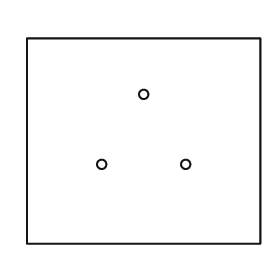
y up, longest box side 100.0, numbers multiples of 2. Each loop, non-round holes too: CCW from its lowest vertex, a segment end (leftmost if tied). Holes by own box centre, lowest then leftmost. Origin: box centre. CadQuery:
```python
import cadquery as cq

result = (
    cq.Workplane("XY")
    .moveTo(-50.0, -44.0)
    .lineTo(50.0, -44.0)
    .lineTo(50.0, 44.0)
    .lineTo(-50.0, 44.0)
    .close()
    .moveTo(-18.0, -10.0)
    .circle(2.0)
    .moveTo(18.0, -10.0)
    .circle(2.0)
    .moveTo(0.0, 20.0)
    .circle(2.0)
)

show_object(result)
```